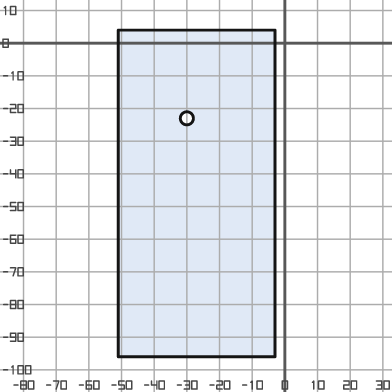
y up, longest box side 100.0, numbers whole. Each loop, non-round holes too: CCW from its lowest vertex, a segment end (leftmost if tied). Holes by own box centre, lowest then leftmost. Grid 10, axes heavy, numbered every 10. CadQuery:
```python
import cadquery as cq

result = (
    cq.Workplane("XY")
    .moveTo(-51.0, -96.0)
    .lineTo(-3.0, -96.0)
    .lineTo(-3.0, 4.0)
    .lineTo(-51.0, 4.0)
    .close()
    .moveTo(-30.0, -23.0)
    .circle(2.0)
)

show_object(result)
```